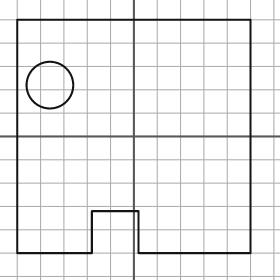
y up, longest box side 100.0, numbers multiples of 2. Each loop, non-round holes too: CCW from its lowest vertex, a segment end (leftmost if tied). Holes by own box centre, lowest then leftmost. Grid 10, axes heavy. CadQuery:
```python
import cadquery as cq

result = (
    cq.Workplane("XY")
    .moveTo(-50.0, -50.0)
    .lineTo(-18.0, -50.0)
    .lineTo(-18.0, -32.0)
    .lineTo(2.0, -32.0)
    .lineTo(2.0, -50.0)
    .lineTo(50.0, -50.0)
    .lineTo(50.0, 50.0)
    .lineTo(-50.0, 50.0)
    .close()
    .moveTo(-36.0, 22.0)
    .circle(10.0)
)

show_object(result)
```